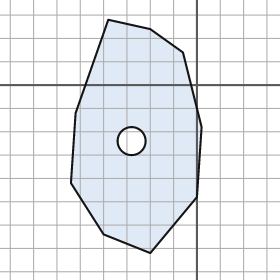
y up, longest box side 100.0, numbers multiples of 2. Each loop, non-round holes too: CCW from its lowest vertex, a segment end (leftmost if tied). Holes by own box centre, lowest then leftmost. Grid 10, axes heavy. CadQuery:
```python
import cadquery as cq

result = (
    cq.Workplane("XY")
    .moveTo(-20.0, -72.0)
    .lineTo(0.0, -48.0)
    .lineTo(2.0, -18.0)
    .lineTo(-6.0, 14.0)
    .lineTo(-20.0, 24.0)
    .lineTo(-38.0, 28.0)
    .lineTo(-52.0, -12.0)
    .lineTo(-54.0, -42.0)
    .lineTo(-40.0, -64.0)
    .close()
    .moveTo(-28.0, -24.0)
    .circle(6.0)
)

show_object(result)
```